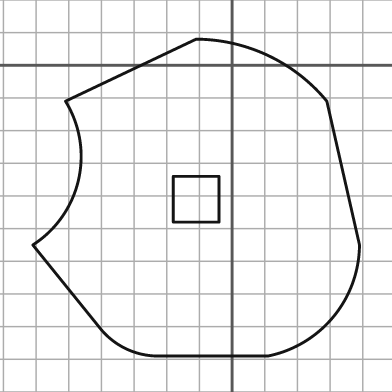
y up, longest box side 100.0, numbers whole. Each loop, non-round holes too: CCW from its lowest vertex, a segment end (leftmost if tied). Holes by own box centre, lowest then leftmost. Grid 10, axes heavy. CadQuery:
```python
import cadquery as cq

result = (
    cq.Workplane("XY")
    .moveTo(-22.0, -89.0)
    .lineTo(11.0, -89.0)
    .threePointArc((31.0, -77.0), (39.0, -55.0))
    .lineTo(29.0, -11.0)
    .threePointArc((11.0, 3.0), (-11.0, 8.0))
    .lineTo(-51.0, -11.0)
    .threePointArc((-47.0, -35.0), (-61.0, -55.0))
    .lineTo(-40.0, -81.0)
    .threePointArc((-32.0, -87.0), (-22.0, -89.0))
    .close()
    .moveTo(-18.0, -48.0)
    .lineTo(-4.0, -48.0)
    .lineTo(-4.0, -34.0)
    .lineTo(-18.0, -34.0)
    .close()
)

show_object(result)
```